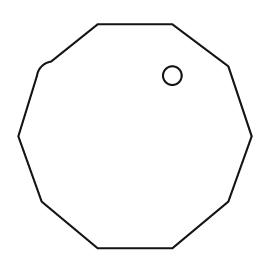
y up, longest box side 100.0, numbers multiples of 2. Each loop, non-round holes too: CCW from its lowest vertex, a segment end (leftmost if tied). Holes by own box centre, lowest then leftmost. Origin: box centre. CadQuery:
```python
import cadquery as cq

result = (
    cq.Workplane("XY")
    .moveTo(-16.0, -48.0)
    .lineTo(16.0, -48.0)
    .lineTo(40.0, -28.0)
    .lineTo(50.0, 0.0)
    .lineTo(40.0, 30.0)
    .lineTo(16.0, 48.0)
    .lineTo(-16.0, 48.0)
    .lineTo(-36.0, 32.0)
    .threePointArc((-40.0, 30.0), (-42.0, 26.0))
    .lineTo(-50.0, 0.0)
    .lineTo(-40.0, -28.0)
    .close()
    .moveTo(16.0, 26.0)
    .circle(4.0)
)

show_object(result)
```